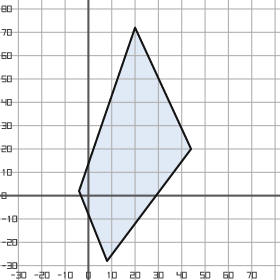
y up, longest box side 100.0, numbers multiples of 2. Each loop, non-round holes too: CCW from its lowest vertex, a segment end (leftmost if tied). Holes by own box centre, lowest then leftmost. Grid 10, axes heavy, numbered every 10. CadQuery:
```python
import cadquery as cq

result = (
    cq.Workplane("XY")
    .moveTo(8.0, -28.0)
    .lineTo(44.0, 20.0)
    .lineTo(20.0, 72.0)
    .lineTo(-4.0, 2.0)
    .close()
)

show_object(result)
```